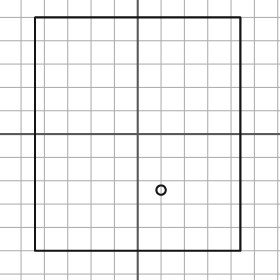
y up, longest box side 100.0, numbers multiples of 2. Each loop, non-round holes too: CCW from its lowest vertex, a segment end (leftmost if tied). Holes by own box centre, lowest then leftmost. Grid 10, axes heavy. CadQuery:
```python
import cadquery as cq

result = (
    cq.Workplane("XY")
    .moveTo(-44.0, -50.0)
    .lineTo(44.0, -50.0)
    .lineTo(44.0, 50.0)
    .lineTo(-44.0, 50.0)
    .close()
    .moveTo(10.0, -24.0)
    .circle(2.0)
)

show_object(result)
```